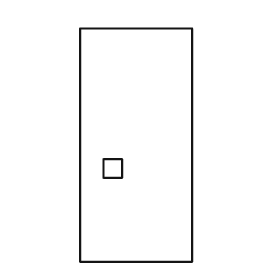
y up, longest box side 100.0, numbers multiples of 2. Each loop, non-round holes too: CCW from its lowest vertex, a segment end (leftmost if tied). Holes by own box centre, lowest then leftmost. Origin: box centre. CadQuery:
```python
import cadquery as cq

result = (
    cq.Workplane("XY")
    .moveTo(-24.0, -50.0)
    .lineTo(24.0, -50.0)
    .lineTo(24.0, 50.0)
    .lineTo(-24.0, 50.0)
    .close()
    .moveTo(-14.0, -14.0)
    .lineTo(-6.0, -14.0)
    .lineTo(-6.0, -6.0)
    .lineTo(-14.0, -6.0)
    .close()
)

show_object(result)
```